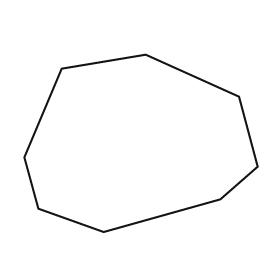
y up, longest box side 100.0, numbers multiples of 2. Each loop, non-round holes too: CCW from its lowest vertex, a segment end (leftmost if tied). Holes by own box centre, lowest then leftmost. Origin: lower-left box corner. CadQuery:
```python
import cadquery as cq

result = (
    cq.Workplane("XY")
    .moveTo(34.0, 0.0)
    .lineTo(84.0, 14.0)
    .lineTo(100.0, 28.0)
    .lineTo(92.0, 58.0)
    .lineTo(52.0, 76.0)
    .lineTo(16.0, 70.0)
    .lineTo(0.0, 32.0)
    .lineTo(6.0, 10.0)
    .close()
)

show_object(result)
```